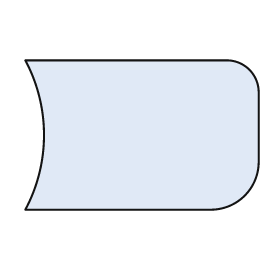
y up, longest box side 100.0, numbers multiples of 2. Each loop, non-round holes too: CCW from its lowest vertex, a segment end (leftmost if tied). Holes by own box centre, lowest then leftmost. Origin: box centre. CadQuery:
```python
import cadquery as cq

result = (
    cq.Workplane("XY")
    .moveTo(-50.0, -32.0)
    .lineTo(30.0, -32.0)
    .threePointArc((44.0, -26.0), (50.0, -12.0))
    .lineTo(50.0, 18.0)
    .threePointArc((46.0, 28.0), (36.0, 32.0))
    .lineTo(-50.0, 32.0)
    .threePointArc((-42.0, 0.0), (-50.0, -32.0))
    .close()
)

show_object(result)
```